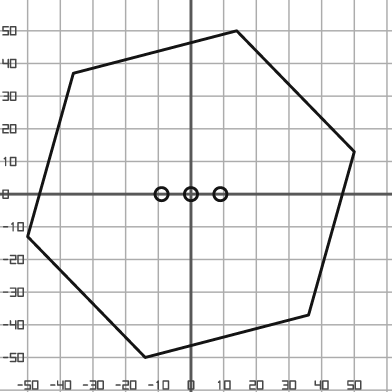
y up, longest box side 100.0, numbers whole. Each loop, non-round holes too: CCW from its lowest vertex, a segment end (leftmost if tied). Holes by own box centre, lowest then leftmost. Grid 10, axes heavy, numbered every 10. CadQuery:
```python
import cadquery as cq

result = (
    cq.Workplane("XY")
    .moveTo(-14.0, -50.0)
    .lineTo(36.0, -37.0)
    .lineTo(50.0, 13.0)
    .lineTo(14.0, 50.0)
    .lineTo(-36.0, 37.0)
    .lineTo(-50.0, -13.0)
    .close()
    .moveTo(-9.0, 0.0)
    .circle(2.0)
    .moveTo(0.0, 0.0)
    .circle(2.0)
    .moveTo(9.0, 0.0)
    .circle(2.0)
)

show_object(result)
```